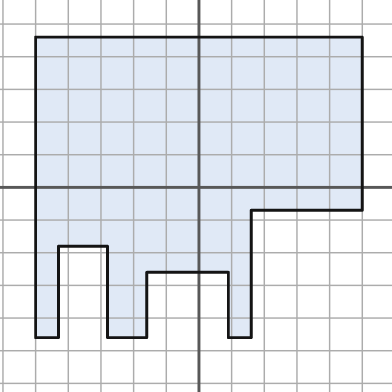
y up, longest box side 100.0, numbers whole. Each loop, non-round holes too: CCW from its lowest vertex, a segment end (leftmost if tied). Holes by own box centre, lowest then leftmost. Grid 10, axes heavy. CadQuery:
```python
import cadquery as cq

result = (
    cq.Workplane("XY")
    .moveTo(-50.0, -46.0)
    .lineTo(-43.0, -46.0)
    .lineTo(-43.0, -18.0)
    .lineTo(-28.0, -18.0)
    .lineTo(-28.0, -46.0)
    .lineTo(-16.0, -46.0)
    .lineTo(-16.0, -26.0)
    .lineTo(9.0, -26.0)
    .lineTo(9.0, -46.0)
    .lineTo(16.0, -46.0)
    .lineTo(16.0, -7.0)
    .lineTo(50.0, -7.0)
    .lineTo(50.0, 46.0)
    .lineTo(-50.0, 46.0)
    .close()
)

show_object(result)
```